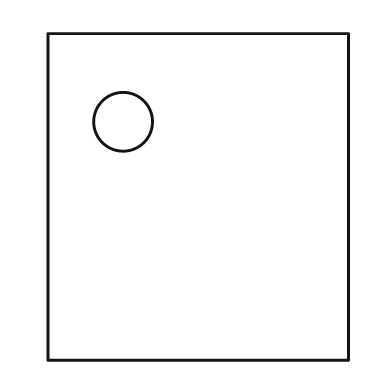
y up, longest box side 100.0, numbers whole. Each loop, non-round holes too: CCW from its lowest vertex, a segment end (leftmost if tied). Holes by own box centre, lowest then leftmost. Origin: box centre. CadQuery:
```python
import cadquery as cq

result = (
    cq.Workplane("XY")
    .moveTo(-46.0, -50.0)
    .lineTo(46.0, -50.0)
    .lineTo(46.0, 50.0)
    .lineTo(-46.0, 50.0)
    .close()
    .moveTo(-23.0, 23.0)
    .circle(9.0)
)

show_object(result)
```